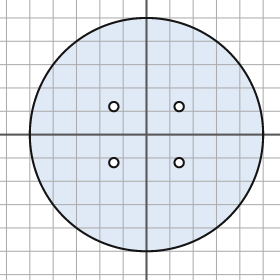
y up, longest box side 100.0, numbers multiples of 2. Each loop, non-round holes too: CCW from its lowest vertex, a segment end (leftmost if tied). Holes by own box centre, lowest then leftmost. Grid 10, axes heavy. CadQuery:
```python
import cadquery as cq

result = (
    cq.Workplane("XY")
    .moveTo(0.0, 0.0)
    .circle(50.0)
    .moveTo(-14.0, -12.0)
    .circle(2.0)
    .moveTo(14.0, -12.0)
    .circle(2.0)
    .moveTo(-14.0, 12.0)
    .circle(2.0)
    .moveTo(14.0, 12.0)
    .circle(2.0)
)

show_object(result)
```